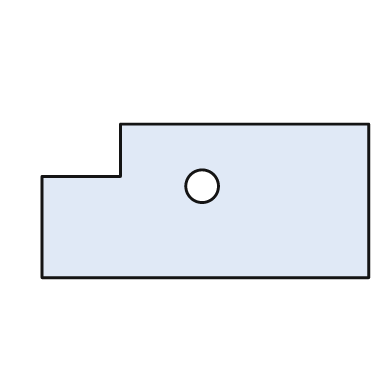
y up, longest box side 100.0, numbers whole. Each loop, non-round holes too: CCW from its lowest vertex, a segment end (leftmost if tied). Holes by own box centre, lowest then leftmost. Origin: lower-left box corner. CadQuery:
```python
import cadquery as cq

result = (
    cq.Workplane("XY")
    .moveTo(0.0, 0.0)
    .lineTo(100.0, 0.0)
    .lineTo(100.0, 47.0)
    .lineTo(24.0, 47.0)
    .lineTo(24.0, 31.0)
    .lineTo(0.0, 31.0)
    .close()
    .moveTo(49.0, 28.0)
    .circle(5.0)
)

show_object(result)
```